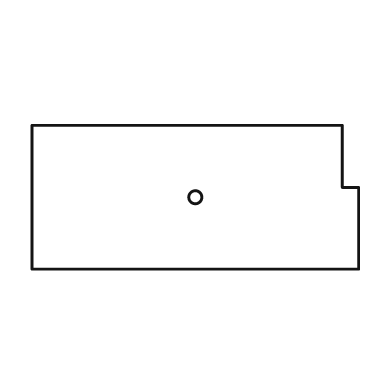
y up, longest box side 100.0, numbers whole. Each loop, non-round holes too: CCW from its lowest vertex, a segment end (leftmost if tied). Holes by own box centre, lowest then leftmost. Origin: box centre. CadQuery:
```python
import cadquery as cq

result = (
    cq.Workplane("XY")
    .moveTo(-50.0, -22.0)
    .lineTo(50.0, -22.0)
    .lineTo(50.0, 3.0)
    .lineTo(45.0, 3.0)
    .lineTo(45.0, 22.0)
    .lineTo(-50.0, 22.0)
    .close()
    .moveTo(0.0, 0.0)
    .circle(2.0)
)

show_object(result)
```